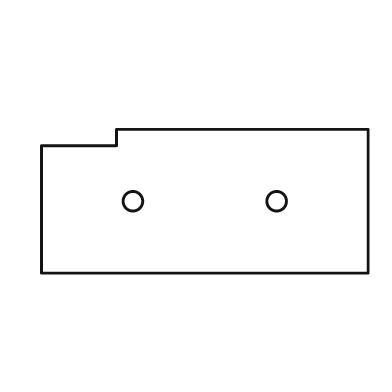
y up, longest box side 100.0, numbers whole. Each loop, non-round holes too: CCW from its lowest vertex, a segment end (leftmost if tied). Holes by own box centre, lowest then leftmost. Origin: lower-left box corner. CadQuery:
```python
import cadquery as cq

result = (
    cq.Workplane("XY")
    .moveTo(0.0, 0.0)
    .lineTo(100.0, 0.0)
    .lineTo(100.0, 44.0)
    .lineTo(23.0, 44.0)
    .lineTo(23.0, 39.0)
    .lineTo(0.0, 39.0)
    .close()
    .moveTo(28.0, 22.0)
    .circle(3.0)
    .moveTo(72.0, 22.0)
    .circle(3.0)
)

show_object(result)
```